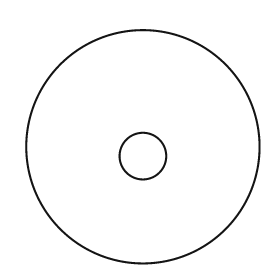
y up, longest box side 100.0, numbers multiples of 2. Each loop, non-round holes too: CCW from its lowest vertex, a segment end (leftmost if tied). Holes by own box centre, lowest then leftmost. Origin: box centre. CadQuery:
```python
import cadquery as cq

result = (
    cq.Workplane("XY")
    .moveTo(0.0, 0.0)
    .circle(50.0)
    .moveTo(0.0, -4.0)
    .circle(10.0)
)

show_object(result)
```